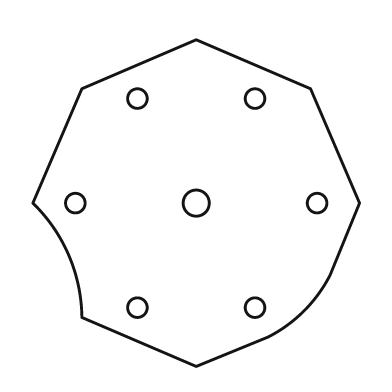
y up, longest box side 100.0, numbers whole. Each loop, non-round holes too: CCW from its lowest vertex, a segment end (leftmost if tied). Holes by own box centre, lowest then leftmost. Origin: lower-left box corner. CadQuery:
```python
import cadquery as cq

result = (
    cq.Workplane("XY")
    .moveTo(50.0, 0.0)
    .lineTo(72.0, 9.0)
    .threePointArc((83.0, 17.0), (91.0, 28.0))
    .lineTo(100.0, 50.0)
    .lineTo(85.0, 85.0)
    .lineTo(50.0, 100.0)
    .lineTo(15.0, 85.0)
    .lineTo(0.0, 50.0)
    .threePointArc((11.0, 34.0), (15.0, 15.0))
    .close()
    .moveTo(32.0, 18.0)
    .circle(3.0)
    .moveTo(68.0, 18.0)
    .circle(3.0)
    .moveTo(13.0, 50.0)
    .circle(3.0)
    .moveTo(50.0, 50.0)
    .circle(4.0)
    .moveTo(87.0, 50.0)
    .circle(3.0)
    .moveTo(32.0, 82.0)
    .circle(3.0)
    .moveTo(68.0, 82.0)
    .circle(3.0)
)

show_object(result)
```